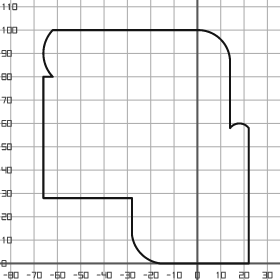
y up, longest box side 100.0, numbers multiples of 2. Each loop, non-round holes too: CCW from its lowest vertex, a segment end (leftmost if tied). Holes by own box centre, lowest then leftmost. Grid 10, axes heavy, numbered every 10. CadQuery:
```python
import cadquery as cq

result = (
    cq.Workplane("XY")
    .moveTo(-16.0, 0.0)
    .lineTo(22.0, 0.0)
    .lineTo(22.0, 58.0)
    .threePointArc((18.0, 60.0), (14.0, 58.0))
    .lineTo(14.0, 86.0)
    .threePointArc((10.0, 96.0), (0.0, 100.0))
    .lineTo(-62.0, 100.0)
    .threePointArc((-66.0, 90.0), (-62.0, 80.0))
    .lineTo(-66.0, 80.0)
    .lineTo(-66.0, 28.0)
    .lineTo(-28.0, 28.0)
    .lineTo(-28.0, 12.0)
    .threePointArc((-24.0, 4.0), (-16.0, 0.0))
    .close()
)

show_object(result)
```